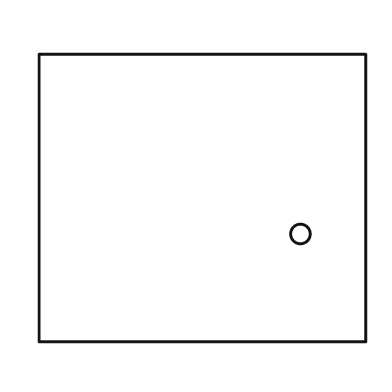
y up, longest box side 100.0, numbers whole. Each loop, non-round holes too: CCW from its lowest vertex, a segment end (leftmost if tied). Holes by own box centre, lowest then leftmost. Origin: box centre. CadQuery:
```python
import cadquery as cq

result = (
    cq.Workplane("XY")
    .moveTo(-50.0, -44.0)
    .lineTo(50.0, -44.0)
    .lineTo(50.0, 44.0)
    .lineTo(-50.0, 44.0)
    .close()
    .moveTo(30.0, -11.0)
    .circle(3.0)
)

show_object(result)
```